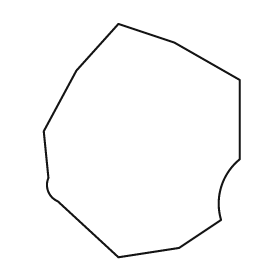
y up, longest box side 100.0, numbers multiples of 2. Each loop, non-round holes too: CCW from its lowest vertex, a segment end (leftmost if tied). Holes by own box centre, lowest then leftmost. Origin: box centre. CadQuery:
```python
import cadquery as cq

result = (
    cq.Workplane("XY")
    .moveTo(-10.0, -50.0)
    .lineTo(16.0, -46.0)
    .lineTo(34.0, -34.0)
    .threePointArc((34.0, -20.0), (42.0, -8.0))
    .lineTo(42.0, 26.0)
    .lineTo(14.0, 42.0)
    .lineTo(-10.0, 50.0)
    .lineTo(-28.0, 30.0)
    .lineTo(-42.0, 4.0)
    .lineTo(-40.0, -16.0)
    .threePointArc((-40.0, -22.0), (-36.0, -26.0))
    .close()
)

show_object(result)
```